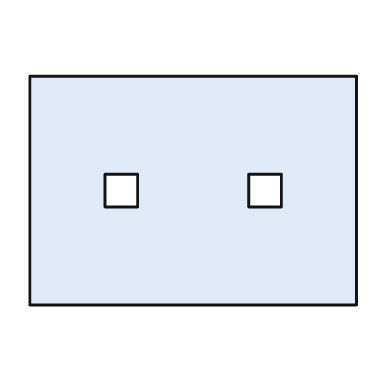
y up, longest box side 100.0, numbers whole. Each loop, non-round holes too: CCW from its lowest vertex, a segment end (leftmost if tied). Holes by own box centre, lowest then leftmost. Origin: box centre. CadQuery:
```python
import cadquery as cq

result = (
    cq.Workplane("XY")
    .moveTo(-50.0, -35.0)
    .lineTo(50.0, -35.0)
    .lineTo(50.0, 35.0)
    .lineTo(-50.0, 35.0)
    .close()
    .moveTo(-27.0, -5.0)
    .lineTo(-17.0, -5.0)
    .lineTo(-17.0, 5.0)
    .lineTo(-27.0, 5.0)
    .close()
    .moveTo(17.0, -5.0)
    .lineTo(27.0, -5.0)
    .lineTo(27.0, 5.0)
    .lineTo(17.0, 5.0)
    .close()
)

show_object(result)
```